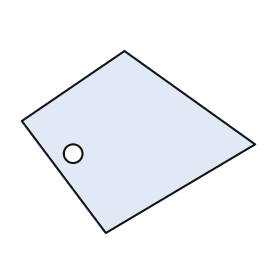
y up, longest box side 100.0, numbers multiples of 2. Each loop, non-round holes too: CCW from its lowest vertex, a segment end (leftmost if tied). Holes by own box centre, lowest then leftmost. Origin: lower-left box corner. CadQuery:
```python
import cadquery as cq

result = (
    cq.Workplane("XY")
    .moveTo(36.0, 0.0)
    .lineTo(100.0, 38.0)
    .lineTo(44.0, 78.0)
    .lineTo(0.0, 48.0)
    .close()
    .moveTo(22.0, 34.0)
    .circle(4.0)
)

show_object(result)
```